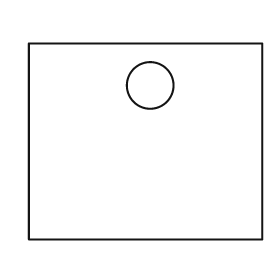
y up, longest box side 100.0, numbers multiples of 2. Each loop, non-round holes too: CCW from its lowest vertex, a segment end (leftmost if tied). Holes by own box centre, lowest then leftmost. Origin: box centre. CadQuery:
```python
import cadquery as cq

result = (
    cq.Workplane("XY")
    .moveTo(-50.0, -42.0)
    .lineTo(50.0, -42.0)
    .lineTo(50.0, 42.0)
    .lineTo(-50.0, 42.0)
    .close()
    .moveTo(2.0, 24.0)
    .circle(10.0)
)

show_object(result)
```